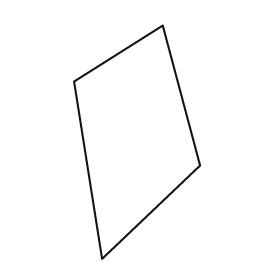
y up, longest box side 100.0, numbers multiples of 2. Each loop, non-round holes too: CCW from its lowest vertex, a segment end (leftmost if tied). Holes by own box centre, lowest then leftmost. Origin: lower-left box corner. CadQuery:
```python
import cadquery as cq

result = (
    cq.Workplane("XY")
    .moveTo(12.0, 0.0)
    .lineTo(54.0, 40.0)
    .lineTo(38.0, 100.0)
    .lineTo(0.0, 76.0)
    .close()
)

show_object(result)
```